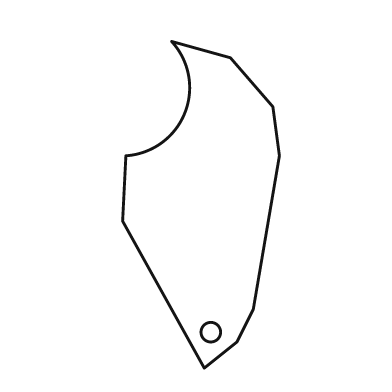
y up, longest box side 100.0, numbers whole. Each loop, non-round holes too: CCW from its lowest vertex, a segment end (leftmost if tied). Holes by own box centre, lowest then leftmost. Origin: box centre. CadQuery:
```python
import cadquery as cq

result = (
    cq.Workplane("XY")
    .moveTo(1.0, -50.0)
    .lineTo(11.0, -42.0)
    .lineTo(16.0, -32.0)
    .lineTo(24.0, 15.0)
    .lineTo(22.0, 30.0)
    .lineTo(9.0, 45.0)
    .lineTo(-9.0, 50.0)
    .threePointArc((-5.0, 28.0), (-23.0, 15.0))
    .lineTo(-24.0, -5.0)
    .close()
    .moveTo(3.0, -39.0)
    .circle(3.0)
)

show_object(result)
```